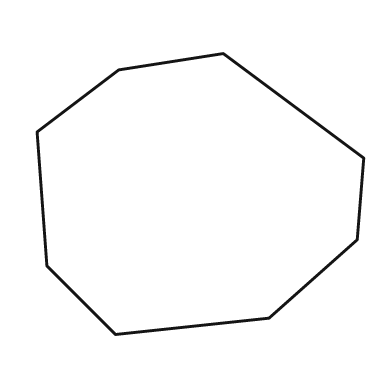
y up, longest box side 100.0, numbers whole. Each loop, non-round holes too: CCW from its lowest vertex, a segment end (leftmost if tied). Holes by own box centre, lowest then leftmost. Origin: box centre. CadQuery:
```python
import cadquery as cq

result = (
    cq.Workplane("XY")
    .moveTo(-26.0, -43.0)
    .lineTo(21.0, -38.0)
    .lineTo(48.0, -14.0)
    .lineTo(50.0, 11.0)
    .lineTo(7.0, 43.0)
    .lineTo(-25.0, 38.0)
    .lineTo(-50.0, 19.0)
    .lineTo(-47.0, -22.0)
    .close()
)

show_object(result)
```